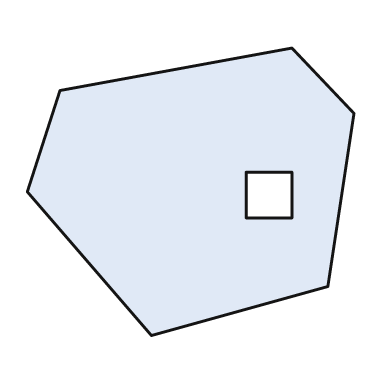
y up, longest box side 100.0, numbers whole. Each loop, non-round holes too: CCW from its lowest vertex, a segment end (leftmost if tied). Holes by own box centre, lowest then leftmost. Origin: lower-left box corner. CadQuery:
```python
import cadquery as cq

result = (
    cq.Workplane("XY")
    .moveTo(38.0, 0.0)
    .lineTo(92.0, 15.0)
    .lineTo(100.0, 68.0)
    .lineTo(81.0, 88.0)
    .lineTo(10.0, 75.0)
    .lineTo(0.0, 44.0)
    .close()
    .moveTo(67.0, 36.0)
    .lineTo(81.0, 36.0)
    .lineTo(81.0, 50.0)
    .lineTo(67.0, 50.0)
    .close()
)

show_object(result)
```